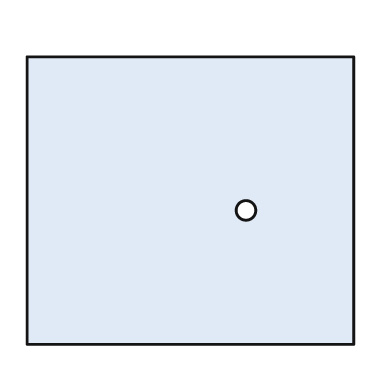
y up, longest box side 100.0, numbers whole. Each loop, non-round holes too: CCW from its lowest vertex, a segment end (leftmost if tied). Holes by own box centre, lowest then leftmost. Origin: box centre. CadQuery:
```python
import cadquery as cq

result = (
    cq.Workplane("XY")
    .moveTo(-50.0, -44.0)
    .lineTo(50.0, -44.0)
    .lineTo(50.0, 44.0)
    .lineTo(-50.0, 44.0)
    .close()
    .moveTo(17.0, -3.0)
    .circle(3.0)
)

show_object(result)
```